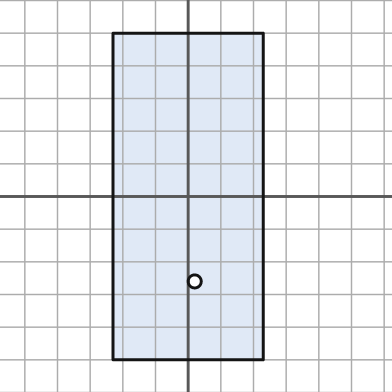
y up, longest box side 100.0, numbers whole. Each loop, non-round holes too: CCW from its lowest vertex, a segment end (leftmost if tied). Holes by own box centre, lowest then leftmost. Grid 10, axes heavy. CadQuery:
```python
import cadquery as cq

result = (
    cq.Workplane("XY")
    .moveTo(-23.0, -50.0)
    .lineTo(23.0, -50.0)
    .lineTo(23.0, 50.0)
    .lineTo(-23.0, 50.0)
    .close()
    .moveTo(2.0, -26.0)
    .circle(2.0)
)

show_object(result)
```